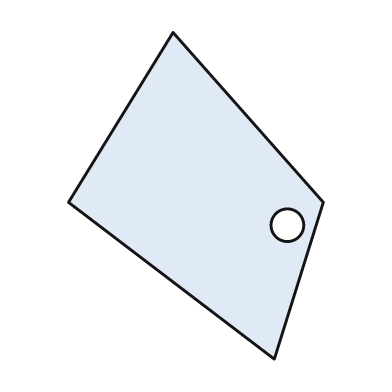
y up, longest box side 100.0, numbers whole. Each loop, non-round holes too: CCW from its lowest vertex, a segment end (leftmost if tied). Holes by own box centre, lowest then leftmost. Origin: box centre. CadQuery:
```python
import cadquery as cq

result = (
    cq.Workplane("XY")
    .moveTo(24.0, -50.0)
    .lineTo(39.0, -2.0)
    .lineTo(-7.0, 50.0)
    .lineTo(-39.0, -2.0)
    .close()
    .moveTo(28.0, -9.0)
    .circle(5.0)
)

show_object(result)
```